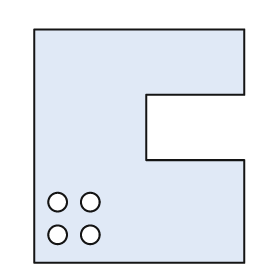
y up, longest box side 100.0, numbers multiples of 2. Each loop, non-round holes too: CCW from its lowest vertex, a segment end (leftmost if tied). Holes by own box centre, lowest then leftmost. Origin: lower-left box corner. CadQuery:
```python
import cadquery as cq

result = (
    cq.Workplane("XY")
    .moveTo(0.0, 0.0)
    .lineTo(90.0, 0.0)
    .lineTo(90.0, 44.0)
    .lineTo(48.0, 44.0)
    .lineTo(48.0, 72.0)
    .lineTo(90.0, 72.0)
    .lineTo(90.0, 100.0)
    .lineTo(0.0, 100.0)
    .close()
    .moveTo(10.0, 12.0)
    .circle(4.0)
    .moveTo(24.0, 12.0)
    .circle(4.0)
    .moveTo(10.0, 26.0)
    .circle(4.0)
    .moveTo(24.0, 26.0)
    .circle(4.0)
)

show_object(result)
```